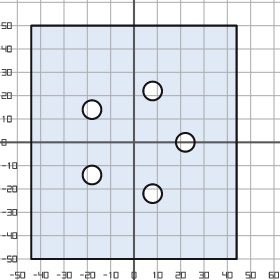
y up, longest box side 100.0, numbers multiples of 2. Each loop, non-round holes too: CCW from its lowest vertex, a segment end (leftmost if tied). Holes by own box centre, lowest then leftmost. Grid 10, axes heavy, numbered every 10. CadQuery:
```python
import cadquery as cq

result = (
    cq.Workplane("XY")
    .moveTo(-44.0, -50.0)
    .lineTo(44.0, -50.0)
    .lineTo(44.0, 50.0)
    .lineTo(-44.0, 50.0)
    .close()
    .moveTo(8.0, -22.0)
    .circle(4.0)
    .moveTo(-18.0, -14.0)
    .circle(4.0)
    .moveTo(22.0, 0.0)
    .circle(4.0)
    .moveTo(-18.0, 14.0)
    .circle(4.0)
    .moveTo(8.0, 22.0)
    .circle(4.0)
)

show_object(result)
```